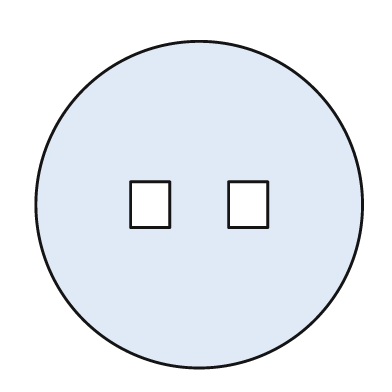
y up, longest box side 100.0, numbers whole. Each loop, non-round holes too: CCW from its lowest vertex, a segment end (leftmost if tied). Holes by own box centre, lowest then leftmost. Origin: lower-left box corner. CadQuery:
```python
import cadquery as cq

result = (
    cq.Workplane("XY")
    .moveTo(50.0, 50.0)
    .circle(50.0)
    .moveTo(29.0, 43.0)
    .lineTo(41.0, 43.0)
    .lineTo(41.0, 57.0)
    .lineTo(29.0, 57.0)
    .close()
    .moveTo(59.0, 43.0)
    .lineTo(71.0, 43.0)
    .lineTo(71.0, 57.0)
    .lineTo(59.0, 57.0)
    .close()
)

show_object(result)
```